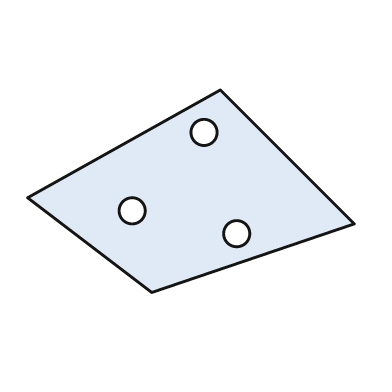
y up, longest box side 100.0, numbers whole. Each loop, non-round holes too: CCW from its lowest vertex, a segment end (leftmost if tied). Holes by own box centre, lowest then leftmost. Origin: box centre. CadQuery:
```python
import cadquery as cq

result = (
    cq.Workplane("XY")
    .moveTo(-12.0, -31.0)
    .lineTo(50.0, -10.0)
    .lineTo(9.0, 31.0)
    .lineTo(-50.0, -2.0)
    .close()
    .moveTo(14.0, -13.0)
    .circle(4.0)
    .moveTo(-18.0, -6.0)
    .circle(4.0)
    .moveTo(4.0, 18.0)
    .circle(4.0)
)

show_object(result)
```